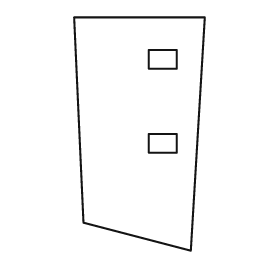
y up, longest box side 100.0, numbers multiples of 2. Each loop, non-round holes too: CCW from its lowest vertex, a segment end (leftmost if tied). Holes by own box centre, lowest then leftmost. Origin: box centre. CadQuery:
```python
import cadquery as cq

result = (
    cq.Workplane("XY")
    .moveTo(22.0, -50.0)
    .lineTo(28.0, 50.0)
    .lineTo(-28.0, 50.0)
    .lineTo(-24.0, -38.0)
    .close()
    .moveTo(4.0, -8.0)
    .lineTo(16.0, -8.0)
    .lineTo(16.0, 0.0)
    .lineTo(4.0, 0.0)
    .close()
    .moveTo(4.0, 28.0)
    .lineTo(16.0, 28.0)
    .lineTo(16.0, 36.0)
    .lineTo(4.0, 36.0)
    .close()
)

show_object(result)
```